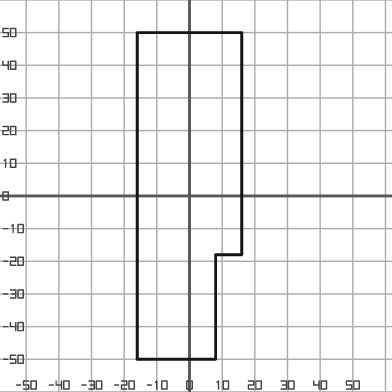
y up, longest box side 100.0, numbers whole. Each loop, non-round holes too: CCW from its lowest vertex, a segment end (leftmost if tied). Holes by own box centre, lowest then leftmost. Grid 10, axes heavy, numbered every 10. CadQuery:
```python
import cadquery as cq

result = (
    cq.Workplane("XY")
    .moveTo(-16.0, -50.0)
    .lineTo(8.0, -50.0)
    .lineTo(8.0, -18.0)
    .lineTo(16.0, -18.0)
    .lineTo(16.0, 50.0)
    .lineTo(-16.0, 50.0)
    .close()
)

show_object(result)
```